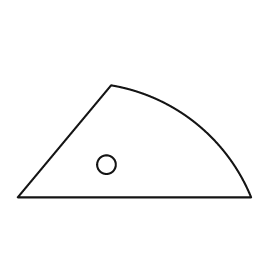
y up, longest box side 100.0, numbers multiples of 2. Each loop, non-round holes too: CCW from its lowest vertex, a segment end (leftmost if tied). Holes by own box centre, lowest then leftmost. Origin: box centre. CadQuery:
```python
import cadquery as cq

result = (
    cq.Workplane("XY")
    .moveTo(-50.0, -24.0)
    .lineTo(50.0, -24.0)
    .threePointArc((26.0, 8.0), (-10.0, 24.0))
    .close()
    .moveTo(-12.0, -10.0)
    .circle(4.0)
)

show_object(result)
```